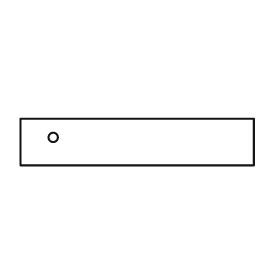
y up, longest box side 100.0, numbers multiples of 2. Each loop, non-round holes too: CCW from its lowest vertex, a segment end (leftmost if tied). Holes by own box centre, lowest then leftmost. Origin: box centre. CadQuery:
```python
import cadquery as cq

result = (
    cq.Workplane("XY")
    .moveTo(-50.0, -10.0)
    .lineTo(50.0, -10.0)
    .lineTo(50.0, 10.0)
    .lineTo(-50.0, 10.0)
    .close()
    .moveTo(-36.0, 2.0)
    .circle(2.0)
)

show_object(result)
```